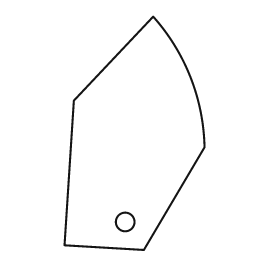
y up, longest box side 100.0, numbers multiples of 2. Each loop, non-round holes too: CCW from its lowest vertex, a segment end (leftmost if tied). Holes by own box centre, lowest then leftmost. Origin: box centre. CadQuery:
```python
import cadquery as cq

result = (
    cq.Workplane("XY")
    .moveTo(4.0, -50.0)
    .lineTo(30.0, -6.0)
    .threePointArc((24.0, 24.0), (8.0, 50.0))
    .lineTo(-26.0, 14.0)
    .lineTo(-30.0, -48.0)
    .close()
    .moveTo(-4.0, -38.0)
    .circle(4.0)
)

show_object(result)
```